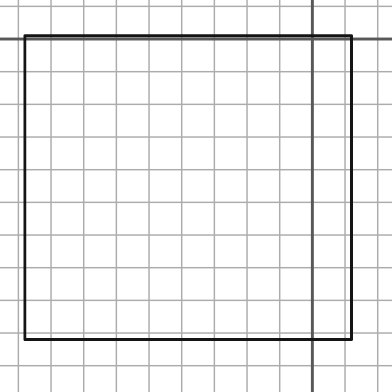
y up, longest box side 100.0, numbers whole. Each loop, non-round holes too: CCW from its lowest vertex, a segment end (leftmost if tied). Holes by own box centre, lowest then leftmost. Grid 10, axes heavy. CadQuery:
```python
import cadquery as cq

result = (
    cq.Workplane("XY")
    .moveTo(-88.0, -92.0)
    .lineTo(12.0, -92.0)
    .lineTo(12.0, 1.0)
    .lineTo(-88.0, 1.0)
    .close()
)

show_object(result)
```